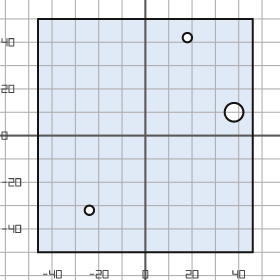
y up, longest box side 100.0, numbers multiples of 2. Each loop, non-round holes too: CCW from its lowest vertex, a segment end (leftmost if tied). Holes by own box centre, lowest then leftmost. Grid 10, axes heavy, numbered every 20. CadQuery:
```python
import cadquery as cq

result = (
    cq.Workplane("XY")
    .moveTo(-46.0, -50.0)
    .lineTo(46.0, -50.0)
    .lineTo(46.0, 50.0)
    .lineTo(-46.0, 50.0)
    .close()
    .moveTo(-24.0, -32.0)
    .circle(2.0)
    .moveTo(38.0, 10.0)
    .circle(4.0)
    .moveTo(18.0, 42.0)
    .circle(2.0)
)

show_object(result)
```